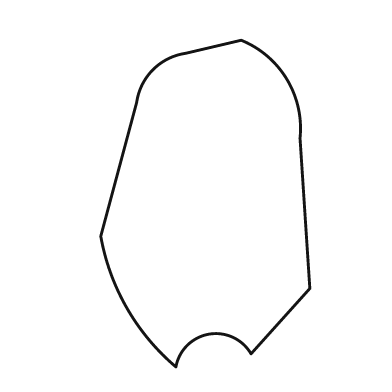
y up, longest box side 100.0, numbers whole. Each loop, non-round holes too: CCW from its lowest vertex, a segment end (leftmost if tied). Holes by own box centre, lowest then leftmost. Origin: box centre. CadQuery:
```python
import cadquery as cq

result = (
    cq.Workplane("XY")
    .moveTo(-9.0, -50.0)
    .threePointArc((1.0, -40.0), (14.0, -46.0))
    .lineTo(32.0, -26.0)
    .lineTo(29.0, 20.0)
    .threePointArc((25.0, 38.0), (11.0, 50.0))
    .lineTo(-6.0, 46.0)
    .threePointArc((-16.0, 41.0), (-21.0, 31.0))
    .lineTo(-32.0, -10.0)
    .threePointArc((-24.0, -32.0), (-9.0, -50.0))
    .close()
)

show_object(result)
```